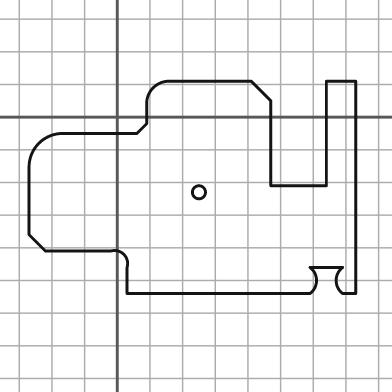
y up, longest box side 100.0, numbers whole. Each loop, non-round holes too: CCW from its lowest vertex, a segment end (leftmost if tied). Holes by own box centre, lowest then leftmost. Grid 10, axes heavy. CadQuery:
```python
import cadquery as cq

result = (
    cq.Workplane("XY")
    .moveTo(3.0, -54.0)
    .lineTo(59.0, -54.0)
    .threePointArc((61.0, -50.0), (59.0, -46.0))
    .lineTo(69.0, -46.0)
    .threePointArc((67.0, -50.0), (69.0, -54.0))
    .lineTo(73.0, -54.0)
    .lineTo(73.0, 11.0)
    .lineTo(64.0, 11.0)
    .lineTo(64.0, -21.0)
    .lineTo(47.0, -21.0)
    .lineTo(47.0, 5.0)
    .lineTo(41.0, 11.0)
    .lineTo(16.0, 11.0)
    .threePointArc((11.0, 9.0), (9.0, 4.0))
    .lineTo(9.0, -2.0)
    .lineTo(6.0, -5.0)
    .lineTo(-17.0, -5.0)
    .threePointArc((-24.0, -8.0), (-27.0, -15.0))
    .lineTo(-27.0, -36.0)
    .lineTo(-22.0, -41.0)
    .lineTo(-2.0, -41.0)
    .threePointArc((2.0, -42.0), (3.0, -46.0))
    .close()
    .moveTo(25.0, -23.0)
    .circle(2.0)
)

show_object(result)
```